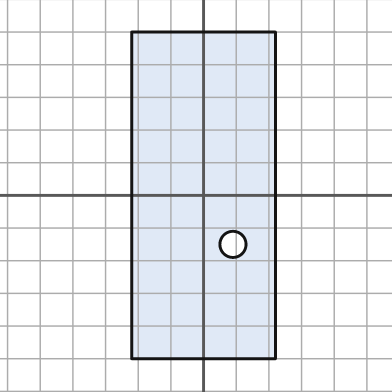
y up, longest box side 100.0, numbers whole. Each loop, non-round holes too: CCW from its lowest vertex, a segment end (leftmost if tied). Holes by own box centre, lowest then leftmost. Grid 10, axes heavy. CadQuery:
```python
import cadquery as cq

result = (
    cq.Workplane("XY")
    .moveTo(-22.0, -50.0)
    .lineTo(22.0, -50.0)
    .lineTo(22.0, 50.0)
    .lineTo(-22.0, 50.0)
    .close()
    .moveTo(9.0, -15.0)
    .circle(4.0)
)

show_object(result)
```